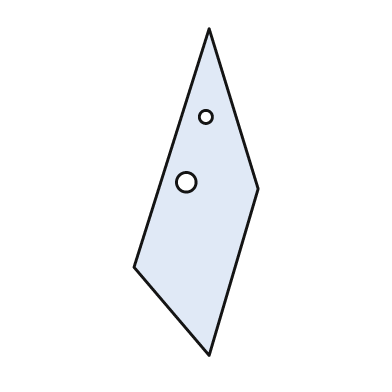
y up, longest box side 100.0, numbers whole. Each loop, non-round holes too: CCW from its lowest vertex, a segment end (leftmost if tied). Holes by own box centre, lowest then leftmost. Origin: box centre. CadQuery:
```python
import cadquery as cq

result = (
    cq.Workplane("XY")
    .moveTo(4.0, -50.0)
    .lineTo(19.0, 1.0)
    .lineTo(4.0, 50.0)
    .lineTo(-19.0, -23.0)
    .close()
    .moveTo(-3.0, 3.0)
    .circle(3.0)
    .moveTo(3.0, 23.0)
    .circle(2.0)
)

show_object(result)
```